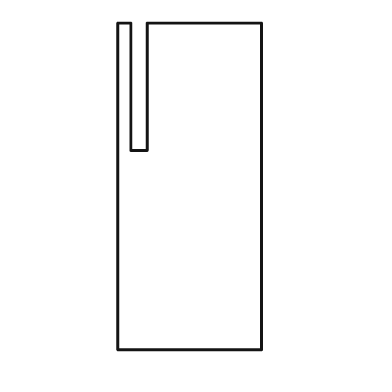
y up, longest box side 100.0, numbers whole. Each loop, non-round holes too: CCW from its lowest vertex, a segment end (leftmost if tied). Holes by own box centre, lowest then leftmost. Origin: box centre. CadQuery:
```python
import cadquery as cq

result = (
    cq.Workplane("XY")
    .moveTo(-22.0, -50.0)
    .lineTo(22.0, -50.0)
    .lineTo(22.0, 50.0)
    .lineTo(-13.0, 50.0)
    .lineTo(-13.0, 11.0)
    .lineTo(-18.0, 11.0)
    .lineTo(-18.0, 50.0)
    .lineTo(-22.0, 50.0)
    .close()
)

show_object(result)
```